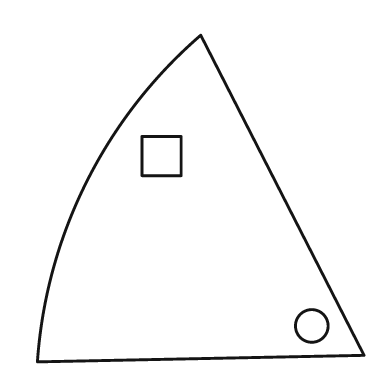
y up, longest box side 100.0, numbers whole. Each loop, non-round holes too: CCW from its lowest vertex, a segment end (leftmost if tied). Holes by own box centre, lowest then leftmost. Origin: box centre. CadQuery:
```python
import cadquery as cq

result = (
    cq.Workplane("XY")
    .moveTo(-50.0, -50.0)
    .lineTo(50.0, -48.0)
    .lineTo(0.0, 50.0)
    .threePointArc((-35.0, 5.0), (-50.0, -50.0))
    .close()
    .moveTo(34.0, -39.0)
    .circle(5.0)
    .moveTo(-18.0, 7.0)
    .lineTo(-6.0, 7.0)
    .lineTo(-6.0, 19.0)
    .lineTo(-18.0, 19.0)
    .close()
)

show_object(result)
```